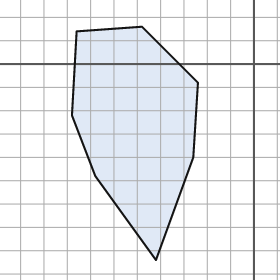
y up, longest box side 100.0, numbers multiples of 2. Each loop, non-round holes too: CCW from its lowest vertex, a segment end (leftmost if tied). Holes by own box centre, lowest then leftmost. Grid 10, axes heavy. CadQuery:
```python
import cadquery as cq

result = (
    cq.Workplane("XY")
    .moveTo(-42.0, -84.0)
    .lineTo(-26.0, -40.0)
    .lineTo(-24.0, -8.0)
    .lineTo(-48.0, 16.0)
    .lineTo(-76.0, 14.0)
    .lineTo(-78.0, -22.0)
    .lineTo(-68.0, -48.0)
    .close()
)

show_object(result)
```